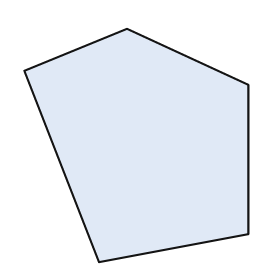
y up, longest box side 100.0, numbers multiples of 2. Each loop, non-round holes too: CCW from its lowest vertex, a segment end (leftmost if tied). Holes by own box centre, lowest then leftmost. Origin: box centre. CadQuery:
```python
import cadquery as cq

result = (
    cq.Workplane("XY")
    .moveTo(-16.0, -50.0)
    .lineTo(48.0, -38.0)
    .lineTo(48.0, 26.0)
    .lineTo(-4.0, 50.0)
    .lineTo(-48.0, 32.0)
    .close()
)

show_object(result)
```